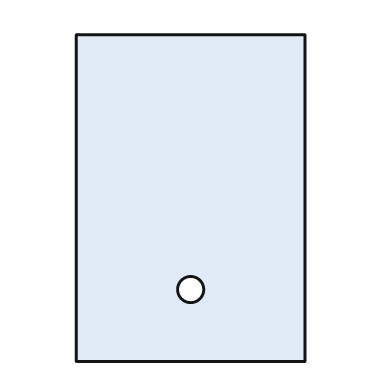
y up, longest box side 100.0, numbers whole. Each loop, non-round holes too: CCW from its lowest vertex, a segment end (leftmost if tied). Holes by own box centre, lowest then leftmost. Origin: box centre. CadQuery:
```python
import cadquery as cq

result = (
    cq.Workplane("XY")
    .moveTo(-35.0, -50.0)
    .lineTo(35.0, -50.0)
    .lineTo(35.0, 50.0)
    .lineTo(-35.0, 50.0)
    .close()
    .moveTo(0.0, -28.0)
    .circle(4.0)
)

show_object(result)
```